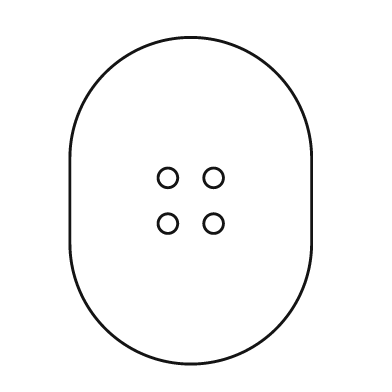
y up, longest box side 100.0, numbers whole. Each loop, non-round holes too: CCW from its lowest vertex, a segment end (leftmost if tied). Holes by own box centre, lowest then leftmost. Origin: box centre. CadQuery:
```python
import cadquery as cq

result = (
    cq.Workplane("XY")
    .moveTo(-37.0, -13.0)
    .threePointArc((0.0, -50.0), (37.0, -13.0))
    .lineTo(37.0, 13.0)
    .threePointArc((0.0, 50.0), (-37.0, 13.0))
    .close()
    .moveTo(-7.0, -7.0)
    .circle(3.0)
    .moveTo(7.0, -7.0)
    .circle(3.0)
    .moveTo(-7.0, 7.0)
    .circle(3.0)
    .moveTo(7.0, 7.0)
    .circle(3.0)
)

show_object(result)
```